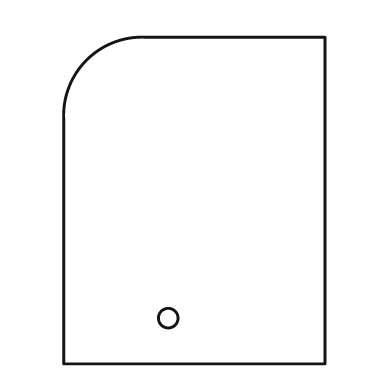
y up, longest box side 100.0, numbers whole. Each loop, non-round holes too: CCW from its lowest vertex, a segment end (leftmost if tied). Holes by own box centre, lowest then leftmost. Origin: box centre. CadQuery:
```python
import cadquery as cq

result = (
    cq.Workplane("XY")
    .moveTo(-40.0, -50.0)
    .lineTo(40.0, -50.0)
    .lineTo(40.0, 50.0)
    .lineTo(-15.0, 50.0)
    .threePointArc((-33.0, 43.0), (-40.0, 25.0))
    .close()
    .moveTo(-8.0, -36.0)
    .circle(3.0)
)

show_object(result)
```